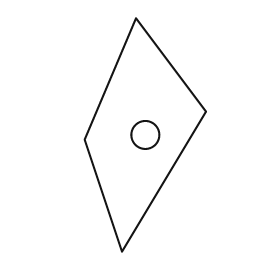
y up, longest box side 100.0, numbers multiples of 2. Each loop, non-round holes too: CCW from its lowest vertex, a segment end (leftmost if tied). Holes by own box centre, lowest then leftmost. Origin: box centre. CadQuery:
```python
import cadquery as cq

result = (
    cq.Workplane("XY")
    .moveTo(-10.0, -50.0)
    .lineTo(26.0, 10.0)
    .lineTo(-4.0, 50.0)
    .lineTo(-26.0, -2.0)
    .close()
    .moveTo(0.0, 0.0)
    .circle(6.0)
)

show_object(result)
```